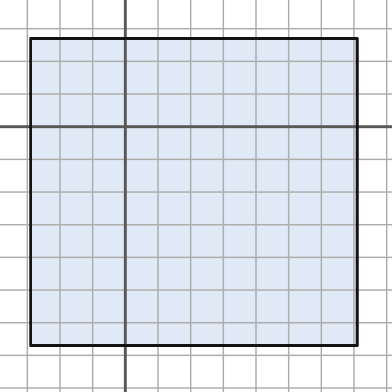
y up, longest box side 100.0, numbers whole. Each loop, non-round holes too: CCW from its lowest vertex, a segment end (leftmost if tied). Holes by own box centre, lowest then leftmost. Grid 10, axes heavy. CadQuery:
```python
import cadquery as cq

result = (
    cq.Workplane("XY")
    .moveTo(-29.0, -67.0)
    .lineTo(71.0, -67.0)
    .lineTo(71.0, 27.0)
    .lineTo(-29.0, 27.0)
    .close()
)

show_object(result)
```